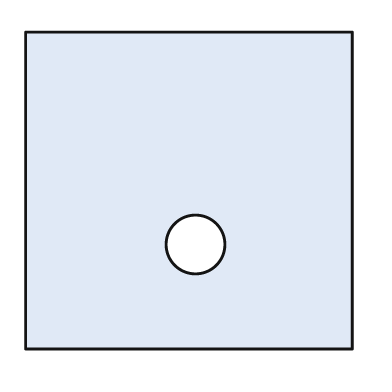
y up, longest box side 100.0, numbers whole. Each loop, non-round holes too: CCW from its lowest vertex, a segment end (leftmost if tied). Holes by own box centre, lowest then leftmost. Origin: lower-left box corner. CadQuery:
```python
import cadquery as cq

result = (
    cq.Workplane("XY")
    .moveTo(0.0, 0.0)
    .lineTo(100.0, 0.0)
    .lineTo(100.0, 97.0)
    .lineTo(0.0, 97.0)
    .close()
    .moveTo(52.0, 32.0)
    .circle(9.0)
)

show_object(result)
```